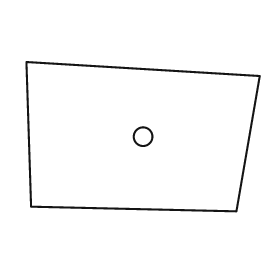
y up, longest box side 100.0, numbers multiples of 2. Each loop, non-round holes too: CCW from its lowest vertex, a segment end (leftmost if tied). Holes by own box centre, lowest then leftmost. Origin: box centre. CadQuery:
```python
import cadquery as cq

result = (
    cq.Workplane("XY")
    .moveTo(40.0, -32.0)
    .lineTo(50.0, 26.0)
    .lineTo(-50.0, 32.0)
    .lineTo(-48.0, -30.0)
    .close()
    .moveTo(0.0, 0.0)
    .circle(4.0)
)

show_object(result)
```